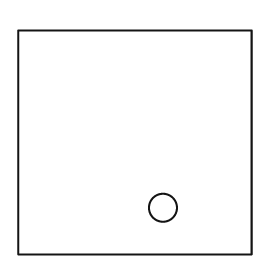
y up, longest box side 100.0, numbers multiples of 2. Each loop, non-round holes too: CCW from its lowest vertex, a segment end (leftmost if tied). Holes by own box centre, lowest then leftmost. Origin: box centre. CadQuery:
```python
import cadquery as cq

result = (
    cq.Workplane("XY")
    .moveTo(-50.0, -48.0)
    .lineTo(50.0, -48.0)
    .lineTo(50.0, 48.0)
    .lineTo(-50.0, 48.0)
    .close()
    .moveTo(12.0, -28.0)
    .circle(6.0)
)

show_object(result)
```